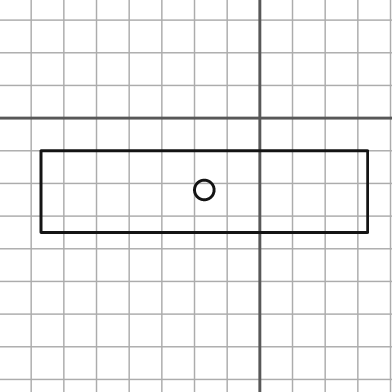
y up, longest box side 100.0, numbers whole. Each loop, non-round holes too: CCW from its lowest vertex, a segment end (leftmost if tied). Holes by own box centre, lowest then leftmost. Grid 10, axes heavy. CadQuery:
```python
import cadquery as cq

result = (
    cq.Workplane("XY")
    .moveTo(-67.0, -35.0)
    .lineTo(33.0, -35.0)
    .lineTo(33.0, -10.0)
    .lineTo(-67.0, -10.0)
    .close()
    .moveTo(-17.0, -22.0)
    .circle(3.0)
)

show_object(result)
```